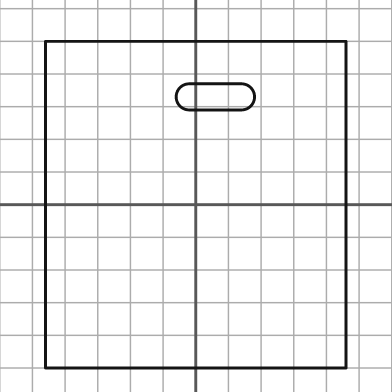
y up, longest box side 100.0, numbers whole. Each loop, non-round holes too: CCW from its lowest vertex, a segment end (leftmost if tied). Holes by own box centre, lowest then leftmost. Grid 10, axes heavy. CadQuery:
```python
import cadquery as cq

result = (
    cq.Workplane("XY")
    .moveTo(-46.0, -50.0)
    .lineTo(46.0, -50.0)
    .lineTo(46.0, 50.0)
    .lineTo(-46.0, 50.0)
    .close()
    .moveTo(-2.0, 29.0)
    .lineTo(14.0, 29.0)
    .threePointArc((18.0, 33.0), (14.0, 37.0))
    .lineTo(-2.0, 37.0)
    .threePointArc((-6.0, 33.0), (-2.0, 29.0))
    .close()
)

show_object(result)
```